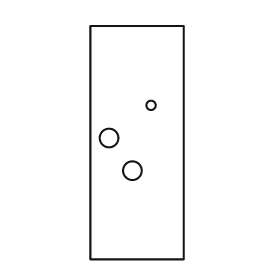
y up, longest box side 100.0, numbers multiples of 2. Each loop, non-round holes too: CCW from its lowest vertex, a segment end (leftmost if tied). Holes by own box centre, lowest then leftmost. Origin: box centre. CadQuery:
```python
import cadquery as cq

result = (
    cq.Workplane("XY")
    .moveTo(-20.0, -50.0)
    .lineTo(20.0, -50.0)
    .lineTo(20.0, 50.0)
    .lineTo(-20.0, 50.0)
    .close()
    .moveTo(-2.0, -12.0)
    .circle(4.0)
    .moveTo(-12.0, 2.0)
    .circle(4.0)
    .moveTo(6.0, 16.0)
    .circle(2.0)
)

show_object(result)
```